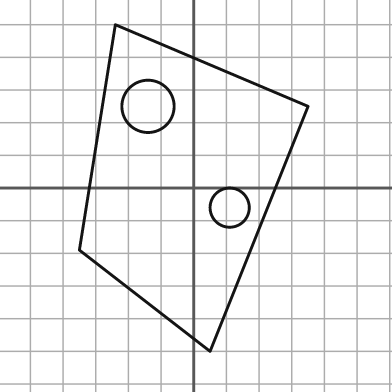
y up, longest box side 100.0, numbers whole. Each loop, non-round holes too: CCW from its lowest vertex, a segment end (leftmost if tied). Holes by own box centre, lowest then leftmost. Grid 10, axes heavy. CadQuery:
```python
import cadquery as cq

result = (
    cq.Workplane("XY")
    .moveTo(5.0, -50.0)
    .lineTo(35.0, 25.0)
    .lineTo(-24.0, 50.0)
    .lineTo(-35.0, -19.0)
    .close()
    .moveTo(11.0, -6.0)
    .circle(6.0)
    .moveTo(-14.0, 25.0)
    .circle(8.0)
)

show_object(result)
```